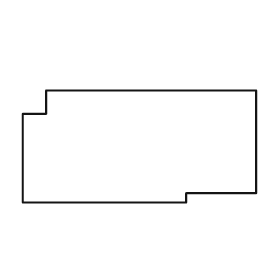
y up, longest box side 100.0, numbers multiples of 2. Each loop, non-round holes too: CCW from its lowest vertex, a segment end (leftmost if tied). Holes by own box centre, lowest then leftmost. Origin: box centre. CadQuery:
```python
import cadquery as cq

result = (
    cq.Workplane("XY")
    .moveTo(-50.0, -24.0)
    .lineTo(20.0, -24.0)
    .lineTo(20.0, -20.0)
    .lineTo(50.0, -20.0)
    .lineTo(50.0, 24.0)
    .lineTo(-40.0, 24.0)
    .lineTo(-40.0, 14.0)
    .lineTo(-50.0, 14.0)
    .close()
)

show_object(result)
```